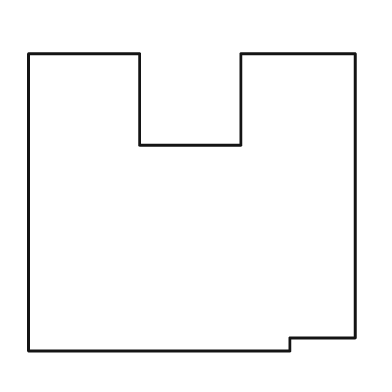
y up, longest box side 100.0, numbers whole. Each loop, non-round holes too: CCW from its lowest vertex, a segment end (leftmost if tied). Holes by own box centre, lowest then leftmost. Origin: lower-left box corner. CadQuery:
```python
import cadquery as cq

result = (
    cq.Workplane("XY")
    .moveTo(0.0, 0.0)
    .lineTo(80.0, 0.0)
    .lineTo(80.0, 4.0)
    .lineTo(100.0, 4.0)
    .lineTo(100.0, 91.0)
    .lineTo(65.0, 91.0)
    .lineTo(65.0, 63.0)
    .lineTo(34.0, 63.0)
    .lineTo(34.0, 91.0)
    .lineTo(0.0, 91.0)
    .close()
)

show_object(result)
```